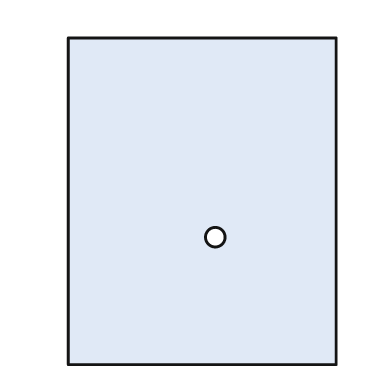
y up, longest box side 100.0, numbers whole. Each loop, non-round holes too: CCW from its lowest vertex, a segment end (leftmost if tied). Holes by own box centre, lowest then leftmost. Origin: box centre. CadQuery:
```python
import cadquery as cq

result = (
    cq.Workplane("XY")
    .moveTo(-41.0, -50.0)
    .lineTo(41.0, -50.0)
    .lineTo(41.0, 50.0)
    .lineTo(-41.0, 50.0)
    .close()
    .moveTo(4.0, -11.0)
    .circle(3.0)
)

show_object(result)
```